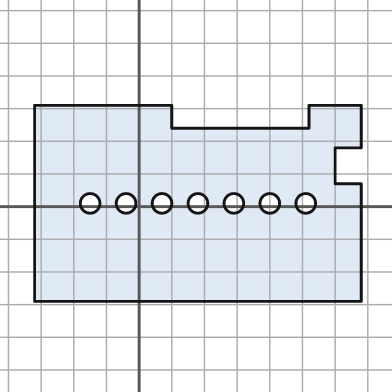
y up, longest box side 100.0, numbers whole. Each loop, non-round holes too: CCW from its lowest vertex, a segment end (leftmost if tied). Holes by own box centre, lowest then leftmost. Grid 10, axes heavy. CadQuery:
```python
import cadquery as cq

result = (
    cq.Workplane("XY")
    .moveTo(-32.0, -29.0)
    .lineTo(68.0, -29.0)
    .lineTo(68.0, 7.0)
    .lineTo(60.0, 7.0)
    .lineTo(60.0, 18.0)
    .lineTo(68.0, 18.0)
    .lineTo(68.0, 31.0)
    .lineTo(52.0, 31.0)
    .lineTo(52.0, 24.0)
    .lineTo(10.0, 24.0)
    .lineTo(10.0, 31.0)
    .lineTo(-32.0, 31.0)
    .close()
    .moveTo(-15.0, 1.0)
    .circle(3.0)
    .moveTo(-4.0, 1.0)
    .circle(3.0)
    .moveTo(7.0, 1.0)
    .circle(3.0)
    .moveTo(18.0, 1.0)
    .circle(3.0)
    .moveTo(29.0, 1.0)
    .circle(3.0)
    .moveTo(40.0, 1.0)
    .circle(3.0)
    .moveTo(51.0, 1.0)
    .circle(3.0)
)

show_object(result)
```